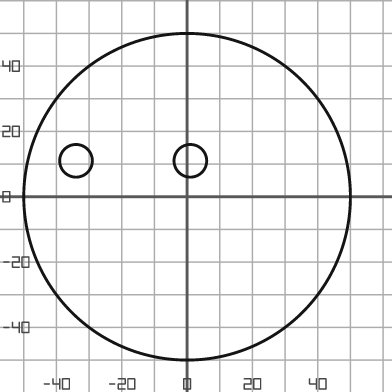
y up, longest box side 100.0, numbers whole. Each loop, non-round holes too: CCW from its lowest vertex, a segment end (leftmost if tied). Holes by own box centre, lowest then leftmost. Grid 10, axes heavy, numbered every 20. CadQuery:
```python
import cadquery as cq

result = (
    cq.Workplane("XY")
    .moveTo(0.0, 0.0)
    .circle(50.0)
    .moveTo(-34.0, 11.0)
    .circle(5.0)
    .moveTo(1.0, 11.0)
    .circle(5.0)
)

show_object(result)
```